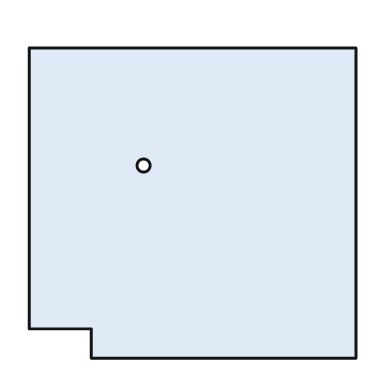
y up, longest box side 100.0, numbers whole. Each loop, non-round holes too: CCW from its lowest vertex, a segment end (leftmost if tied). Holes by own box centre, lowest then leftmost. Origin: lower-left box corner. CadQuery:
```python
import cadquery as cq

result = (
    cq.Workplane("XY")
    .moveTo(19.0, 0.0)
    .lineTo(100.0, 0.0)
    .lineTo(100.0, 95.0)
    .lineTo(0.0, 95.0)
    .lineTo(0.0, 9.0)
    .lineTo(19.0, 9.0)
    .close()
    .moveTo(35.0, 59.0)
    .circle(2.0)
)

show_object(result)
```